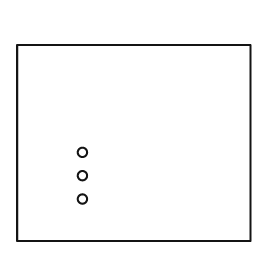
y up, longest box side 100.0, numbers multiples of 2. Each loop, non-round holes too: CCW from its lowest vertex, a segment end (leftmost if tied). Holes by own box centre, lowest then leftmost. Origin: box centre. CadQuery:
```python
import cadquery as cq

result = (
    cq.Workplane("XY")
    .moveTo(-50.0, -42.0)
    .lineTo(50.0, -42.0)
    .lineTo(50.0, 42.0)
    .lineTo(-50.0, 42.0)
    .close()
    .moveTo(-22.0, -24.0)
    .circle(2.0)
    .moveTo(-22.0, -14.0)
    .circle(2.0)
    .moveTo(-22.0, -4.0)
    .circle(2.0)
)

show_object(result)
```